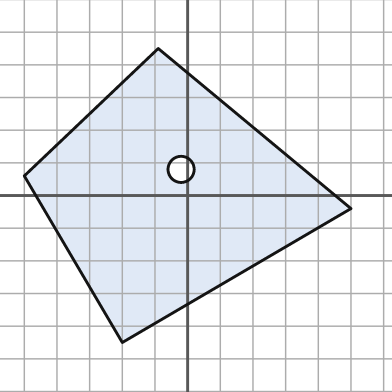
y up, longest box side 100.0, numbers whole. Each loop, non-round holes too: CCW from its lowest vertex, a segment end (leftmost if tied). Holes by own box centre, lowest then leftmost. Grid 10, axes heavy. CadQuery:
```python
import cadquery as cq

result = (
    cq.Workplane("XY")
    .moveTo(-20.0, -45.0)
    .lineTo(50.0, -4.0)
    .lineTo(-9.0, 45.0)
    .lineTo(-50.0, 6.0)
    .close()
    .moveTo(-2.0, 8.0)
    .circle(4.0)
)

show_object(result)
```